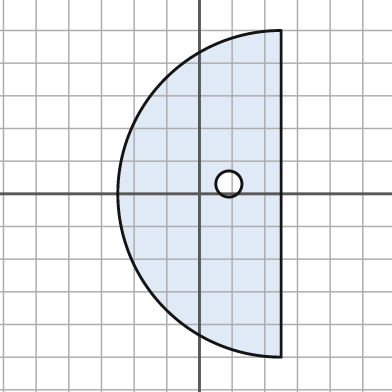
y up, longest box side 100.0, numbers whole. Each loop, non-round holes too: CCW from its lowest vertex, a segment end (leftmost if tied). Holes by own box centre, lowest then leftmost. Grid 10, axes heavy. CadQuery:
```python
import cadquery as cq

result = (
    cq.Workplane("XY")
    .moveTo(25.0, -50.0)
    .lineTo(25.0, 50.0)
    .threePointArc((-25.0, 0.0), (25.0, -50.0))
    .close()
    .moveTo(9.0, 3.0)
    .circle(4.0)
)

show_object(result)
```